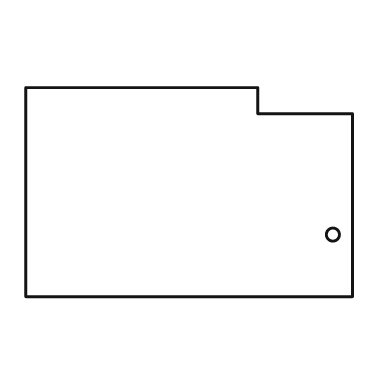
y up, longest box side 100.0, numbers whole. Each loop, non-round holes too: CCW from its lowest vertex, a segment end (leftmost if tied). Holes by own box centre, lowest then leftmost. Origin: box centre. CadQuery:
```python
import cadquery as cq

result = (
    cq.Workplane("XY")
    .moveTo(-50.0, -32.0)
    .lineTo(50.0, -32.0)
    .lineTo(50.0, 24.0)
    .lineTo(21.0, 24.0)
    .lineTo(21.0, 32.0)
    .lineTo(-50.0, 32.0)
    .close()
    .moveTo(44.0, -13.0)
    .circle(2.0)
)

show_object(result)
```